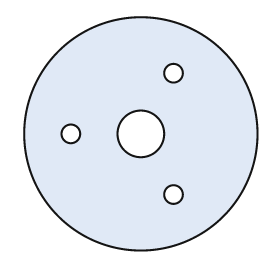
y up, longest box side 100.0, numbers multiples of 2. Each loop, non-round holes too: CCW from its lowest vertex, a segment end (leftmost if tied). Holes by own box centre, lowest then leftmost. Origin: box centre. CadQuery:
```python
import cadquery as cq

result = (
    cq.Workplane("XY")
    .moveTo(0.0, 0.0)
    .circle(50.0)
    .moveTo(14.0, -26.0)
    .circle(4.0)
    .moveTo(-30.0, 0.0)
    .circle(4.0)
    .moveTo(0.0, 0.0)
    .circle(10.0)
    .moveTo(14.0, 26.0)
    .circle(4.0)
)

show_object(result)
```